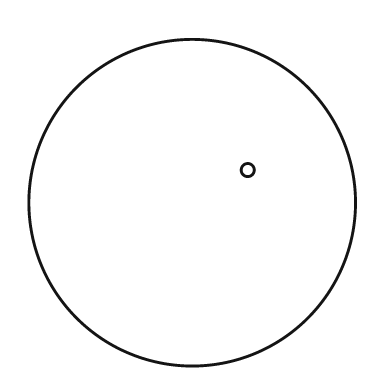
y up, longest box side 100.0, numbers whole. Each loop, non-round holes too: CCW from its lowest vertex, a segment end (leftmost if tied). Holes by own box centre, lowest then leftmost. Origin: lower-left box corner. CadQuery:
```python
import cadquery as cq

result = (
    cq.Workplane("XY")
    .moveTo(50.0, 50.0)
    .circle(50.0)
    .moveTo(67.0, 60.0)
    .circle(2.0)
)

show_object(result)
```